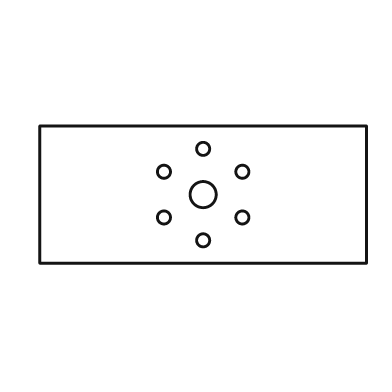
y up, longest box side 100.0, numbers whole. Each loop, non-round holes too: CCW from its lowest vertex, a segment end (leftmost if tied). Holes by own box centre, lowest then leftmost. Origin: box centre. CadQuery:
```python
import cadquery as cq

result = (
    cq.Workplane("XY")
    .moveTo(-50.0, -21.0)
    .lineTo(50.0, -21.0)
    .lineTo(50.0, 21.0)
    .lineTo(-50.0, 21.0)
    .close()
    .moveTo(0.0, -14.0)
    .circle(2.0)
    .moveTo(-12.0, -7.0)
    .circle(2.0)
    .moveTo(12.0, -7.0)
    .circle(2.0)
    .moveTo(0.0, 0.0)
    .circle(4.0)
    .moveTo(-12.0, 7.0)
    .circle(2.0)
    .moveTo(12.0, 7.0)
    .circle(2.0)
    .moveTo(0.0, 14.0)
    .circle(2.0)
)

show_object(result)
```